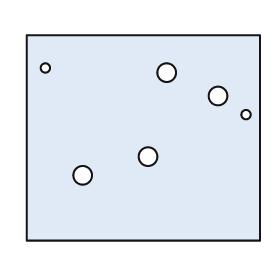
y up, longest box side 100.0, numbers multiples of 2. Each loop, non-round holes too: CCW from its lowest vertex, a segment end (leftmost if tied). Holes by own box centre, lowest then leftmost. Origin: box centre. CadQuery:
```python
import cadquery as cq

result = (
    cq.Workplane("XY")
    .moveTo(-50.0, -44.0)
    .lineTo(50.0, -44.0)
    .lineTo(50.0, 44.0)
    .lineTo(-50.0, 44.0)
    .close()
    .moveTo(-26.0, -16.0)
    .circle(4.0)
    .moveTo(2.0, -8.0)
    .circle(4.0)
    .moveTo(44.0, 10.0)
    .circle(2.0)
    .moveTo(32.0, 18.0)
    .circle(4.0)
    .moveTo(10.0, 28.0)
    .circle(4.0)
    .moveTo(-42.0, 30.0)
    .circle(2.0)
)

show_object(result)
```